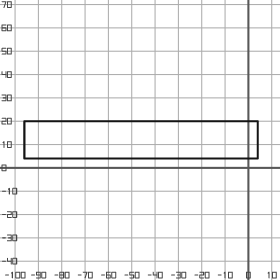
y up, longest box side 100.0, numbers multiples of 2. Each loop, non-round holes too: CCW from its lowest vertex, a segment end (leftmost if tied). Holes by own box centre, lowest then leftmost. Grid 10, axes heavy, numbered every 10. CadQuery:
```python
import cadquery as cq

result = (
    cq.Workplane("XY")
    .moveTo(-96.0, 4.0)
    .lineTo(4.0, 4.0)
    .lineTo(4.0, 20.0)
    .lineTo(-96.0, 20.0)
    .close()
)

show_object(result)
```